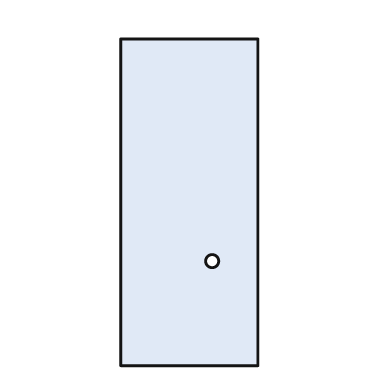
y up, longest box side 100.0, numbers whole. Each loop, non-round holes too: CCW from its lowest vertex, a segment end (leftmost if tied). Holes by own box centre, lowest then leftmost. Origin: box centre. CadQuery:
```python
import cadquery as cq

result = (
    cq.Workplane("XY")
    .moveTo(-21.0, -50.0)
    .lineTo(21.0, -50.0)
    .lineTo(21.0, 50.0)
    .lineTo(-21.0, 50.0)
    .close()
    .moveTo(7.0, -18.0)
    .circle(2.0)
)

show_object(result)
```